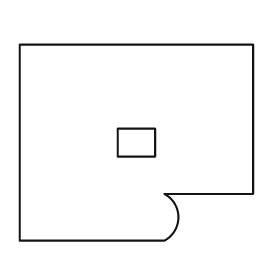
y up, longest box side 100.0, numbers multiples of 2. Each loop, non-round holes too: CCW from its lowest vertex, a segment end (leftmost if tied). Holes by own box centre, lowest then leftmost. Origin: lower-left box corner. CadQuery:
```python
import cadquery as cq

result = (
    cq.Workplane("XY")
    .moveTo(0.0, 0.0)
    .lineTo(62.0, 0.0)
    .threePointArc((68.0, 10.0), (62.0, 20.0))
    .lineTo(100.0, 20.0)
    .lineTo(100.0, 84.0)
    .lineTo(0.0, 84.0)
    .close()
    .moveTo(42.0, 36.0)
    .lineTo(58.0, 36.0)
    .lineTo(58.0, 48.0)
    .lineTo(42.0, 48.0)
    .close()
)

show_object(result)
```